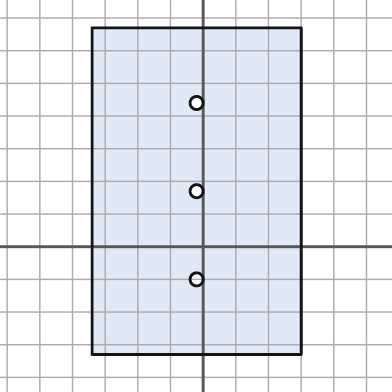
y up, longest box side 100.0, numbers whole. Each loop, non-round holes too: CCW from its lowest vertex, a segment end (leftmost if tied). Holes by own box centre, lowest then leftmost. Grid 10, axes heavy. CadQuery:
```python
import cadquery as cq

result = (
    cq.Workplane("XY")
    .moveTo(-34.0, -33.0)
    .lineTo(30.0, -33.0)
    .lineTo(30.0, 67.0)
    .lineTo(-34.0, 67.0)
    .close()
    .moveTo(-2.0, -10.0)
    .circle(2.0)
    .moveTo(-2.0, 17.0)
    .circle(2.0)
    .moveTo(-2.0, 44.0)
    .circle(2.0)
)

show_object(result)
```